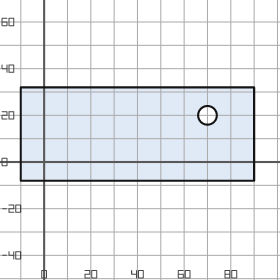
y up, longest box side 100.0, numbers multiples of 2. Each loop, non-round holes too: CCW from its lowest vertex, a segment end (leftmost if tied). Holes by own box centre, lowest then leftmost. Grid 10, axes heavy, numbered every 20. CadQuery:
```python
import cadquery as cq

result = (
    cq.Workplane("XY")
    .moveTo(-10.0, -8.0)
    .lineTo(90.0, -8.0)
    .lineTo(90.0, 32.0)
    .lineTo(-10.0, 32.0)
    .close()
    .moveTo(70.0, 20.0)
    .circle(4.0)
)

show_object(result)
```